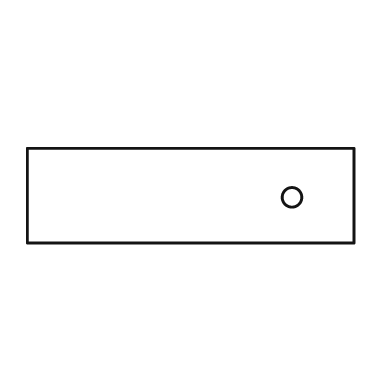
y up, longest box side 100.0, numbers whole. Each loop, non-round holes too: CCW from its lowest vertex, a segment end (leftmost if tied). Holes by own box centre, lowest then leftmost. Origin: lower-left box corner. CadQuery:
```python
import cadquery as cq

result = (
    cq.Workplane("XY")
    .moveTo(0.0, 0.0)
    .lineTo(100.0, 0.0)
    .lineTo(100.0, 29.0)
    .lineTo(0.0, 29.0)
    .close()
    .moveTo(81.0, 14.0)
    .circle(3.0)
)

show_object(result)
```